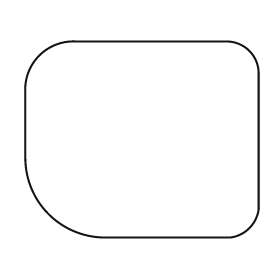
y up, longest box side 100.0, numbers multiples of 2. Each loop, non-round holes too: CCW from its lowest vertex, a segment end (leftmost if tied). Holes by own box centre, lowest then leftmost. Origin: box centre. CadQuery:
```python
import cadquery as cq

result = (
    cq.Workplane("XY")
    .moveTo(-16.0, -42.0)
    .lineTo(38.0, -42.0)
    .threePointArc((46.0, -38.0), (50.0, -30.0))
    .lineTo(50.0, 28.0)
    .threePointArc((46.0, 38.0), (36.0, 42.0))
    .lineTo(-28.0, 42.0)
    .threePointArc((-44.0, 36.0), (-50.0, 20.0))
    .lineTo(-50.0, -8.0)
    .threePointArc((-40.0, -32.0), (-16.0, -42.0))
    .close()
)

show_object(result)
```